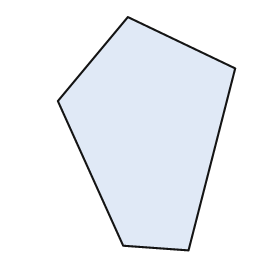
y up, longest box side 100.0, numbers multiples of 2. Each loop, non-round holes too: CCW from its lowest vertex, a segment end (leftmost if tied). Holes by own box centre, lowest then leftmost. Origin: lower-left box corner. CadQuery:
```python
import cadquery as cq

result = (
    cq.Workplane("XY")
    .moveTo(56.0, 0.0)
    .lineTo(76.0, 78.0)
    .lineTo(30.0, 100.0)
    .lineTo(0.0, 64.0)
    .lineTo(28.0, 2.0)
    .close()
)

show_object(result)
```